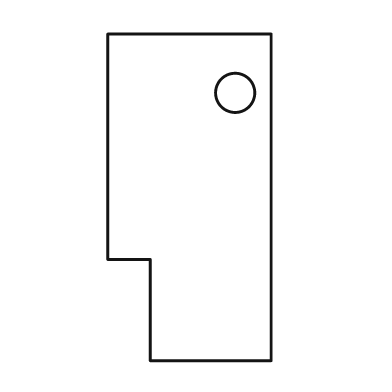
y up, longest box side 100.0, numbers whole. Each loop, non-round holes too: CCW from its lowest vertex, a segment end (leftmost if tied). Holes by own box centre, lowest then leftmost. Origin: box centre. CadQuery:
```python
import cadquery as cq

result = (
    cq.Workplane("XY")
    .moveTo(-12.0, -50.0)
    .lineTo(25.0, -50.0)
    .lineTo(25.0, 50.0)
    .lineTo(-25.0, 50.0)
    .lineTo(-25.0, -19.0)
    .lineTo(-12.0, -19.0)
    .close()
    .moveTo(14.0, 32.0)
    .circle(6.0)
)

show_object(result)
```